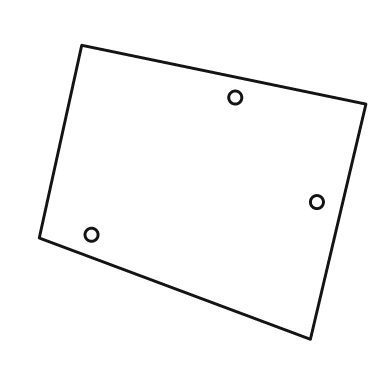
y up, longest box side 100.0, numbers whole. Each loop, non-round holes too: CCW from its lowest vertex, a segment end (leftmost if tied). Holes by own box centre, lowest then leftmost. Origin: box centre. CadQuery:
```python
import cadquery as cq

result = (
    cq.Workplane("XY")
    .moveTo(33.0, -45.0)
    .lineTo(50.0, 27.0)
    .lineTo(-37.0, 45.0)
    .lineTo(-50.0, -14.0)
    .close()
    .moveTo(-34.0, -13.0)
    .circle(2.0)
    .moveTo(35.0, -3.0)
    .circle(2.0)
    .moveTo(10.0, 29.0)
    .circle(2.0)
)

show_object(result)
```